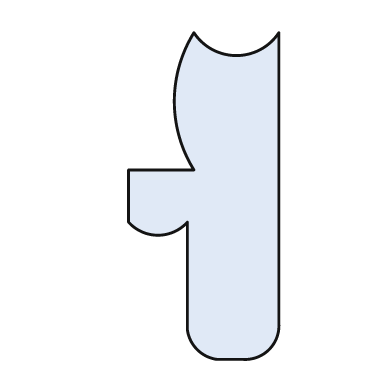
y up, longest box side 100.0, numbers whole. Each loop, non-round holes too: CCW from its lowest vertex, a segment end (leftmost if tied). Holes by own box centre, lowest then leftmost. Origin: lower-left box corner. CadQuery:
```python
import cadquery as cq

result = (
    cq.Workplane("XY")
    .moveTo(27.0, 0.0)
    .lineTo(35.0, 0.0)
    .threePointArc((43.0, 3.0), (46.0, 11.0))
    .lineTo(46.0, 100.0)
    .threePointArc((33.0, 93.0), (20.0, 100.0))
    .threePointArc((14.0, 79.0), (20.0, 58.0))
    .lineTo(0.0, 58.0)
    .lineTo(0.0, 42.0)
    .threePointArc((9.0, 38.0), (18.0, 42.0))
    .lineTo(18.0, 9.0)
    .threePointArc((21.0, 3.0), (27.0, 0.0))
    .close()
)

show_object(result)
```